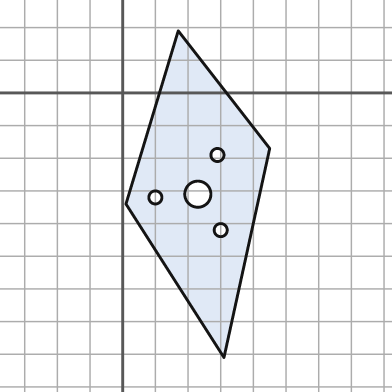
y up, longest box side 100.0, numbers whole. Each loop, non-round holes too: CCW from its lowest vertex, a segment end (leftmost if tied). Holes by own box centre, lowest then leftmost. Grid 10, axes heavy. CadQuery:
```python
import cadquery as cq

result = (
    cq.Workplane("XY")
    .moveTo(31.0, -81.0)
    .lineTo(45.0, -17.0)
    .lineTo(17.0, 19.0)
    .lineTo(1.0, -34.0)
    .close()
    .moveTo(30.0, -42.0)
    .circle(2.0)
    .moveTo(10.0, -32.0)
    .circle(2.0)
    .moveTo(23.0, -31.0)
    .circle(4.0)
    .moveTo(29.0, -19.0)
    .circle(2.0)
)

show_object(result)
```